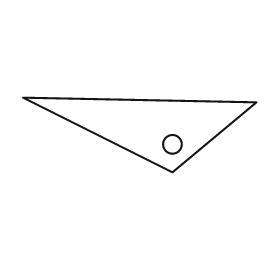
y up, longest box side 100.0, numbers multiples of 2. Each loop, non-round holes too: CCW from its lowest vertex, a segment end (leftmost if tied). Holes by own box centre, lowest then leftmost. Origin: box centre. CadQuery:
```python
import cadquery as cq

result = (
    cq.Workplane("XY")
    .moveTo(14.0, -16.0)
    .lineTo(50.0, 14.0)
    .lineTo(-50.0, 16.0)
    .close()
    .moveTo(14.0, -4.0)
    .circle(4.0)
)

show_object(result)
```